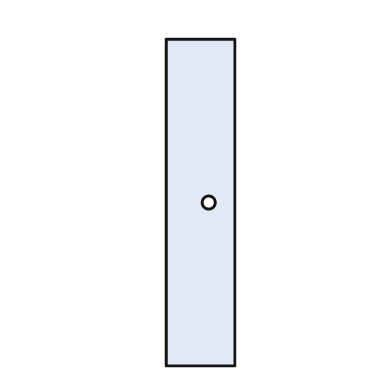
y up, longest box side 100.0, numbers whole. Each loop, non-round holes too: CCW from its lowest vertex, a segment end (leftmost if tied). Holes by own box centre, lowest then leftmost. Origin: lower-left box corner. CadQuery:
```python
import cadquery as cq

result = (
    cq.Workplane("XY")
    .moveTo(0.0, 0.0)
    .lineTo(21.0, 0.0)
    .lineTo(21.0, 100.0)
    .lineTo(0.0, 100.0)
    .close()
    .moveTo(13.0, 50.0)
    .circle(2.0)
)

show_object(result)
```